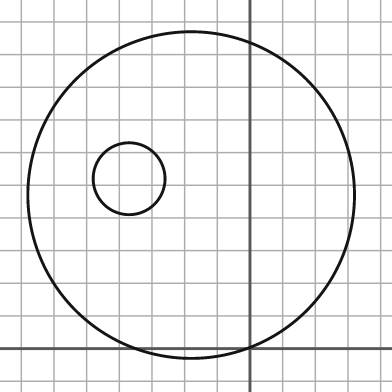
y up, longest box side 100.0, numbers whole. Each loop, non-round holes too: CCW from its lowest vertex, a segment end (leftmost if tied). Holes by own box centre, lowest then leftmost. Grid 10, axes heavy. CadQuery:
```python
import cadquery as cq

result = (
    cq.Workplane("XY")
    .moveTo(-18.0, 47.0)
    .circle(50.0)
    .moveTo(-37.0, 52.0)
    .circle(11.0)
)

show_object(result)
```